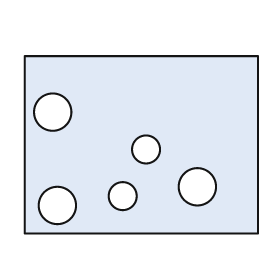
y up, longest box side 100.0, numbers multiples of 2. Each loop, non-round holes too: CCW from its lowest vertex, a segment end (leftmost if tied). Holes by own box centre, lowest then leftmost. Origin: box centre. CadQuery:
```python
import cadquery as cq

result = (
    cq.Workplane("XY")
    .moveTo(-50.0, -38.0)
    .lineTo(50.0, -38.0)
    .lineTo(50.0, 38.0)
    .lineTo(-50.0, 38.0)
    .close()
    .moveTo(-36.0, -26.0)
    .circle(8.0)
    .moveTo(-8.0, -22.0)
    .circle(6.0)
    .moveTo(24.0, -18.0)
    .circle(8.0)
    .moveTo(2.0, -2.0)
    .circle(6.0)
    .moveTo(-38.0, 14.0)
    .circle(8.0)
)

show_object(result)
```